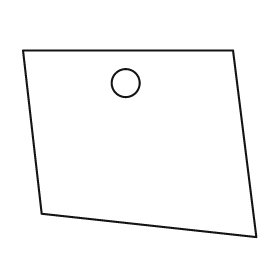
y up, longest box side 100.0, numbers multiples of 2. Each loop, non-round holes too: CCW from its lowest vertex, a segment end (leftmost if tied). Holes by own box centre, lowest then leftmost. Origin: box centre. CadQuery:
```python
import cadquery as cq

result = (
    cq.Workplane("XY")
    .moveTo(50.0, -40.0)
    .lineTo(40.0, 40.0)
    .lineTo(-50.0, 40.0)
    .lineTo(-42.0, -30.0)
    .close()
    .moveTo(-6.0, 26.0)
    .circle(6.0)
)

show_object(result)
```